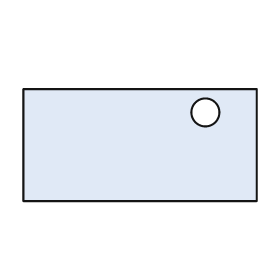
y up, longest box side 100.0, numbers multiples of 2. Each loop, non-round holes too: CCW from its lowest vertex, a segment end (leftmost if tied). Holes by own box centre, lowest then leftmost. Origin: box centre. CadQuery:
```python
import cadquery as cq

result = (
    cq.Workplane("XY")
    .moveTo(-50.0, -24.0)
    .lineTo(50.0, -24.0)
    .lineTo(50.0, 24.0)
    .lineTo(-50.0, 24.0)
    .close()
    .moveTo(28.0, 14.0)
    .circle(6.0)
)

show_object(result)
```